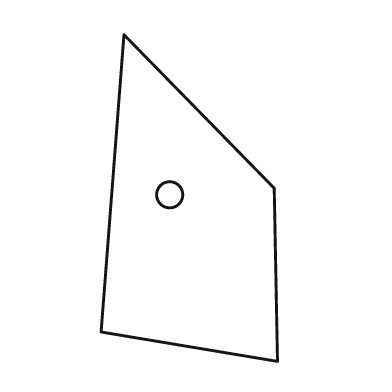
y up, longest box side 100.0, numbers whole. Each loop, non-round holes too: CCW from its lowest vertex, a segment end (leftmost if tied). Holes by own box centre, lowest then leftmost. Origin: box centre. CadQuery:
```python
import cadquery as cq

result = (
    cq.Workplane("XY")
    .moveTo(27.0, -50.0)
    .lineTo(26.0, 3.0)
    .lineTo(-20.0, 50.0)
    .lineTo(-27.0, -41.0)
    .close()
    .moveTo(-6.0, 1.0)
    .circle(4.0)
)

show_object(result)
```